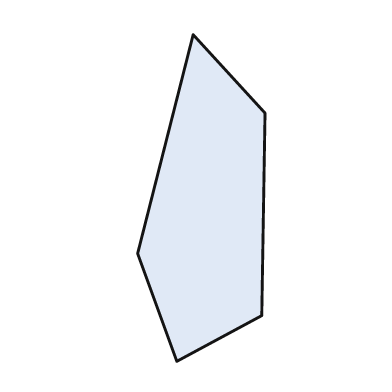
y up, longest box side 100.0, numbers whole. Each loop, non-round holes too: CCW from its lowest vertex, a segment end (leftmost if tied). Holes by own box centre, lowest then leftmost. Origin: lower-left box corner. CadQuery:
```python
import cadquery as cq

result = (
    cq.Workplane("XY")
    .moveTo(12.0, 0.0)
    .lineTo(38.0, 14.0)
    .lineTo(39.0, 76.0)
    .lineTo(17.0, 100.0)
    .lineTo(0.0, 33.0)
    .close()
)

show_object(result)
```